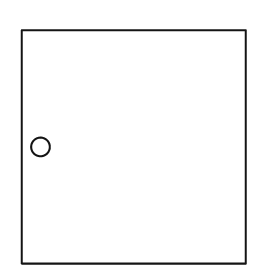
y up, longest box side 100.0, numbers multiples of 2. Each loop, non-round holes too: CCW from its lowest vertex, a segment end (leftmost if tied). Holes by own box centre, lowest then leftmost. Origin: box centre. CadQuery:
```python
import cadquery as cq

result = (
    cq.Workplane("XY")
    .moveTo(-48.0, -50.0)
    .lineTo(48.0, -50.0)
    .lineTo(48.0, 50.0)
    .lineTo(-48.0, 50.0)
    .close()
    .moveTo(-40.0, 0.0)
    .circle(4.0)
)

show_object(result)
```